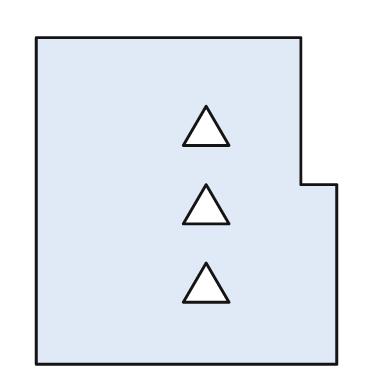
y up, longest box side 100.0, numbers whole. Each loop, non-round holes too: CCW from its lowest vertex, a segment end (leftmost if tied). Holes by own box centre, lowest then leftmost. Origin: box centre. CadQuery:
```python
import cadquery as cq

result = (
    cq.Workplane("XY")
    .moveTo(-46.0, -50.0)
    .lineTo(46.0, -50.0)
    .lineTo(46.0, 5.0)
    .lineTo(35.0, 5.0)
    .lineTo(35.0, 50.0)
    .lineTo(-46.0, 50.0)
    .close()
    .moveTo(-1.0, -31.0)
    .lineTo(13.0, -31.0)
    .lineTo(6.0, -19.0)
    .close()
    .moveTo(-1.0, -7.0)
    .lineTo(13.0, -7.0)
    .lineTo(6.0, 5.0)
    .close()
    .moveTo(-1.0, 17.0)
    .lineTo(13.0, 17.0)
    .lineTo(6.0, 29.0)
    .close()
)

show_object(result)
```